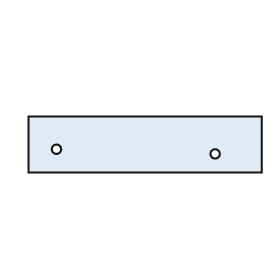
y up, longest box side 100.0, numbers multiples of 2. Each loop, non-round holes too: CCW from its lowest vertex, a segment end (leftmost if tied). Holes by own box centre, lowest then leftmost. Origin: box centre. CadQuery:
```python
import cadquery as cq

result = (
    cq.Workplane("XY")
    .moveTo(-50.0, -12.0)
    .lineTo(50.0, -12.0)
    .lineTo(50.0, 12.0)
    .lineTo(-50.0, 12.0)
    .close()
    .moveTo(30.0, -4.0)
    .circle(2.0)
    .moveTo(-38.0, -2.0)
    .circle(2.0)
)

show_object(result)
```